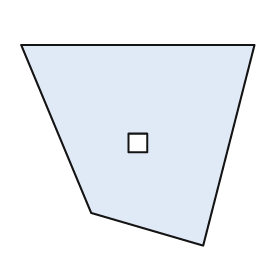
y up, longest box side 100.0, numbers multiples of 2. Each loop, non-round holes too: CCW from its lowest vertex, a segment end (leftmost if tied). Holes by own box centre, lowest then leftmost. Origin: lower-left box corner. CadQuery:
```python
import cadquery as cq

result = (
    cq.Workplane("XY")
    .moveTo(78.0, 0.0)
    .lineTo(100.0, 86.0)
    .lineTo(0.0, 86.0)
    .lineTo(30.0, 14.0)
    .close()
    .moveTo(46.0, 40.0)
    .lineTo(54.0, 40.0)
    .lineTo(54.0, 48.0)
    .lineTo(46.0, 48.0)
    .close()
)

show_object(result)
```